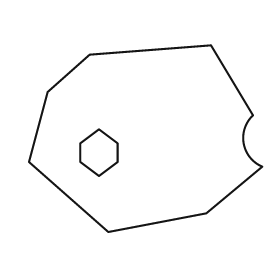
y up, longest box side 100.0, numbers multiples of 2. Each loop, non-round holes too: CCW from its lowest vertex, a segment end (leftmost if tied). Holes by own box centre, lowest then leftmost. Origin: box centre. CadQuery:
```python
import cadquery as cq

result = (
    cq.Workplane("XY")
    .moveTo(-16.0, -40.0)
    .lineTo(26.0, -32.0)
    .lineTo(50.0, -12.0)
    .threePointArc((42.0, -2.0), (46.0, 10.0))
    .lineTo(28.0, 40.0)
    .lineTo(-24.0, 36.0)
    .lineTo(-42.0, 20.0)
    .lineTo(-50.0, -10.0)
    .close()
    .moveTo(-20.0, -16.0)
    .lineTo(-12.0, -10.0)
    .lineTo(-12.0, -2.0)
    .lineTo(-20.0, 4.0)
    .lineTo(-28.0, -2.0)
    .lineTo(-28.0, -10.0)
    .close()
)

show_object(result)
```